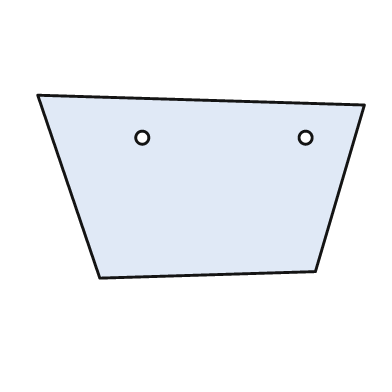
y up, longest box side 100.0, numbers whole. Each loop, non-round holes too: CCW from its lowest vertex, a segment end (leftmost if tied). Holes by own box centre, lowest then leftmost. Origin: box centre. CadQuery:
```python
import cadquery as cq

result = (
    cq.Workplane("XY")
    .moveTo(-31.0, -28.0)
    .lineTo(35.0, -26.0)
    .lineTo(50.0, 25.0)
    .lineTo(-50.0, 28.0)
    .close()
    .moveTo(-18.0, 15.0)
    .circle(2.0)
    .moveTo(32.0, 15.0)
    .circle(2.0)
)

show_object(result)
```